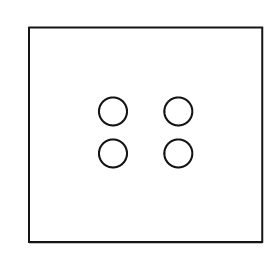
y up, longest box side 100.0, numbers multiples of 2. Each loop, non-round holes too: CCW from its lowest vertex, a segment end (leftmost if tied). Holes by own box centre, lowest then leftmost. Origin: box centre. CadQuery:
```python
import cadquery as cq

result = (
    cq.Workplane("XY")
    .moveTo(-50.0, -46.0)
    .lineTo(50.0, -46.0)
    .lineTo(50.0, 46.0)
    .lineTo(-50.0, 46.0)
    .close()
    .moveTo(-14.0, -8.0)
    .circle(6.0)
    .moveTo(14.0, -8.0)
    .circle(6.0)
    .moveTo(-14.0, 10.0)
    .circle(6.0)
    .moveTo(14.0, 10.0)
    .circle(6.0)
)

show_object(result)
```